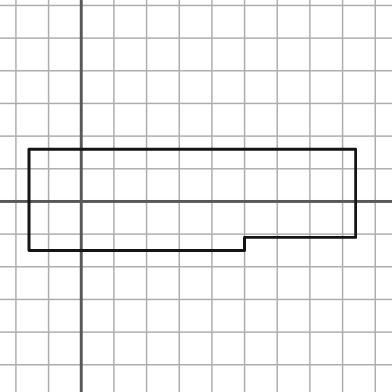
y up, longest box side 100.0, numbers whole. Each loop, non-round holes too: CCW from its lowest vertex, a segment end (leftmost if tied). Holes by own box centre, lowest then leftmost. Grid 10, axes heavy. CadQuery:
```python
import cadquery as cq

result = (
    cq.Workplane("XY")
    .moveTo(-16.0, -15.0)
    .lineTo(50.0, -15.0)
    .lineTo(50.0, -11.0)
    .lineTo(84.0, -11.0)
    .lineTo(84.0, 16.0)
    .lineTo(-16.0, 16.0)
    .close()
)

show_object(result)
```